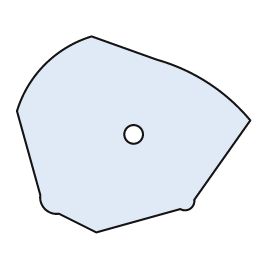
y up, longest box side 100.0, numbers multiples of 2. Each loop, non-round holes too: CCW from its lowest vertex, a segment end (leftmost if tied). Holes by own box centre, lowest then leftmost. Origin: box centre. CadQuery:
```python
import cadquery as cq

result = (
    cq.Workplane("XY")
    .moveTo(-16.0, -42.0)
    .lineTo(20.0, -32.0)
    .threePointArc((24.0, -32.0), (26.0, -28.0))
    .lineTo(50.0, 6.0)
    .threePointArc((32.0, 22.0), (10.0, 32.0))
    .lineTo(-18.0, 42.0)
    .threePointArc((-38.0, 30.0), (-50.0, 10.0))
    .lineTo(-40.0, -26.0)
    .threePointArc((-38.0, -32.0), (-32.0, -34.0))
    .close()
    .moveTo(0.0, 0.0)
    .circle(4.0)
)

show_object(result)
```